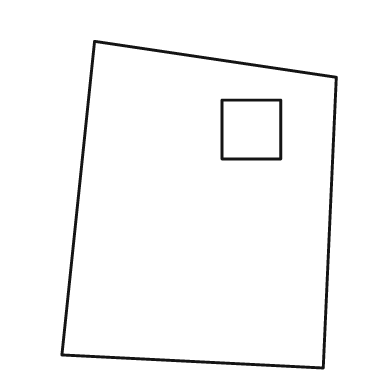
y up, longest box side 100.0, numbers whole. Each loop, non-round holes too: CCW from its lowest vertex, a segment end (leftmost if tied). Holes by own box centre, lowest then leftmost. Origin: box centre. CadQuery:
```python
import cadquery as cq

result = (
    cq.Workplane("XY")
    .moveTo(38.0, -50.0)
    .lineTo(42.0, 39.0)
    .lineTo(-32.0, 50.0)
    .lineTo(-42.0, -46.0)
    .close()
    .moveTo(7.0, 14.0)
    .lineTo(25.0, 14.0)
    .lineTo(25.0, 32.0)
    .lineTo(7.0, 32.0)
    .close()
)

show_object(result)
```